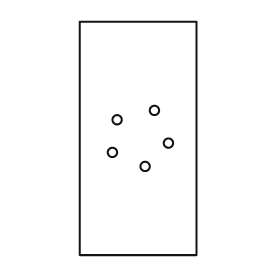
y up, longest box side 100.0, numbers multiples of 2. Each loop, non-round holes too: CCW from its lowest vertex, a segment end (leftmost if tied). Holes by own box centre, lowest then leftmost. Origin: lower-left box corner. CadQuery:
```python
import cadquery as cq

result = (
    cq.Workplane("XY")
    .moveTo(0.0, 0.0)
    .lineTo(50.0, 0.0)
    .lineTo(50.0, 100.0)
    .lineTo(0.0, 100.0)
    .close()
    .moveTo(28.0, 38.0)
    .circle(2.0)
    .moveTo(14.0, 44.0)
    .circle(2.0)
    .moveTo(38.0, 48.0)
    .circle(2.0)
    .moveTo(16.0, 58.0)
    .circle(2.0)
    .moveTo(32.0, 62.0)
    .circle(2.0)
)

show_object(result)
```